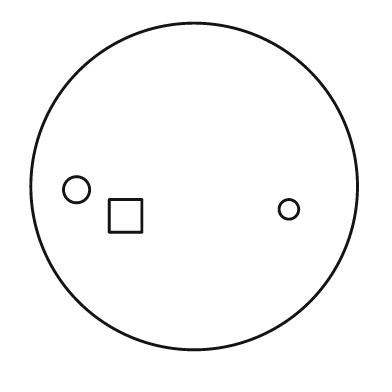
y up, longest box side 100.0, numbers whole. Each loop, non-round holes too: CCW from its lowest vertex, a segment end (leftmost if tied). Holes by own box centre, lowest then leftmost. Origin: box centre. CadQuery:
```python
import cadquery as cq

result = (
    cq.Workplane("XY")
    .moveTo(0.0, 0.0)
    .circle(50.0)
    .moveTo(-26.0, -14.0)
    .lineTo(-16.0, -14.0)
    .lineTo(-16.0, -4.0)
    .lineTo(-26.0, -4.0)
    .close()
    .moveTo(29.0, -7.0)
    .circle(3.0)
    .moveTo(-36.0, -1.0)
    .circle(4.0)
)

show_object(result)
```